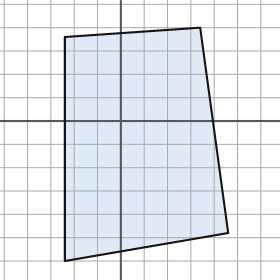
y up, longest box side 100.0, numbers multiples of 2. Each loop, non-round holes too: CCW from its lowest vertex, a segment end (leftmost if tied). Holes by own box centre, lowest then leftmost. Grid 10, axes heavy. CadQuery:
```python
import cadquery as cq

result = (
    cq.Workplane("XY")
    .moveTo(-24.0, -60.0)
    .lineTo(46.0, -48.0)
    .lineTo(34.0, 40.0)
    .lineTo(-24.0, 36.0)
    .close()
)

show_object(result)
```